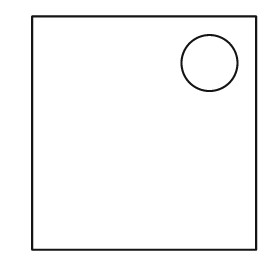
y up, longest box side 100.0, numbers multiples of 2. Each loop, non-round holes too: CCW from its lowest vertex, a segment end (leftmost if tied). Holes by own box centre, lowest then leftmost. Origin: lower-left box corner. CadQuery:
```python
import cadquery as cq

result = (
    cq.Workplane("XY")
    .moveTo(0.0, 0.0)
    .lineTo(96.0, 0.0)
    .lineTo(96.0, 100.0)
    .lineTo(0.0, 100.0)
    .close()
    .moveTo(76.0, 80.0)
    .circle(12.0)
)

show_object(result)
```